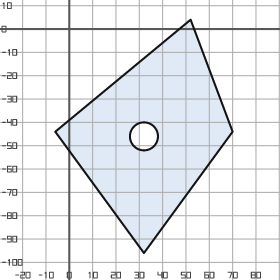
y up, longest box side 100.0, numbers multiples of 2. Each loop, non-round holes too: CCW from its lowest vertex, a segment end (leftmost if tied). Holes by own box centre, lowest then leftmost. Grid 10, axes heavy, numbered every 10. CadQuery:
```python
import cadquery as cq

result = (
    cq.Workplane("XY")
    .moveTo(32.0, -96.0)
    .lineTo(70.0, -44.0)
    .lineTo(52.0, 4.0)
    .lineTo(-6.0, -44.0)
    .close()
    .moveTo(32.0, -46.0)
    .circle(6.0)
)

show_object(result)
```